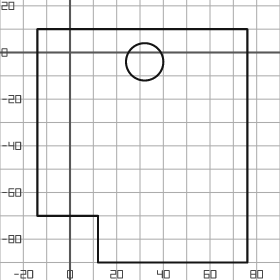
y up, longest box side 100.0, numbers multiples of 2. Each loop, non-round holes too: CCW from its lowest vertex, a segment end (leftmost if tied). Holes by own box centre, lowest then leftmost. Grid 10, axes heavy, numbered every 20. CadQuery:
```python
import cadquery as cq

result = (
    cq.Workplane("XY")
    .moveTo(12.0, -90.0)
    .lineTo(76.0, -90.0)
    .lineTo(76.0, 10.0)
    .lineTo(-14.0, 10.0)
    .lineTo(-14.0, -70.0)
    .lineTo(12.0, -70.0)
    .close()
    .moveTo(32.0, -4.0)
    .circle(8.0)
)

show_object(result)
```